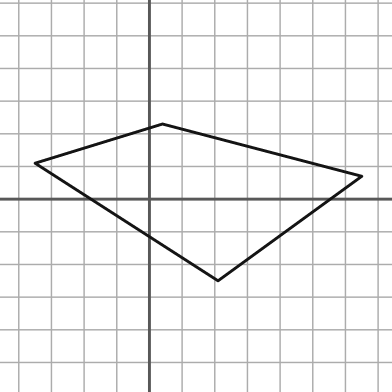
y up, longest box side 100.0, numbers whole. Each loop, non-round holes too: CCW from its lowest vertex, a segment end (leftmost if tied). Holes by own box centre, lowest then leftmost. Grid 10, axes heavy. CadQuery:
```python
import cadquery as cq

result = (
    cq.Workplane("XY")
    .moveTo(21.0, -25.0)
    .lineTo(65.0, 7.0)
    .lineTo(4.0, 23.0)
    .lineTo(-35.0, 11.0)
    .close()
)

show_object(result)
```